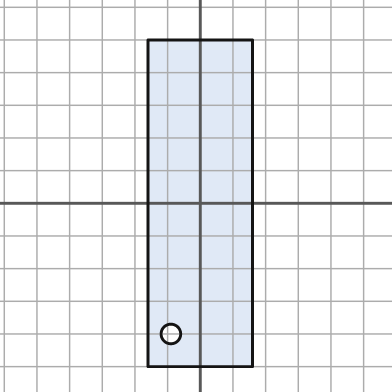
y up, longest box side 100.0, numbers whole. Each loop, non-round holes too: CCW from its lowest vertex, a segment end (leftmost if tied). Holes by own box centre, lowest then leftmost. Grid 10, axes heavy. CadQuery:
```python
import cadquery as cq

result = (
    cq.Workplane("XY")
    .moveTo(-16.0, -50.0)
    .lineTo(16.0, -50.0)
    .lineTo(16.0, 50.0)
    .lineTo(-16.0, 50.0)
    .close()
    .moveTo(-9.0, -40.0)
    .circle(3.0)
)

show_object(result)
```